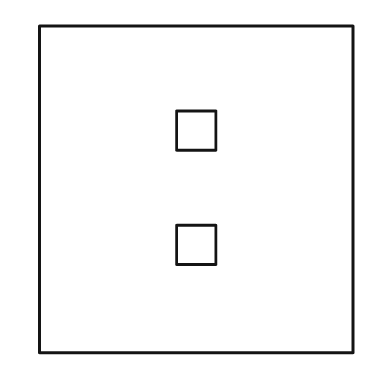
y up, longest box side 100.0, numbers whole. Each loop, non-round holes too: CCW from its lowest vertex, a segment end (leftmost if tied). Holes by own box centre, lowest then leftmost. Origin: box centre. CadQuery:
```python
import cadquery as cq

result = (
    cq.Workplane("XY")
    .moveTo(-48.0, -50.0)
    .lineTo(48.0, -50.0)
    .lineTo(48.0, 50.0)
    .lineTo(-48.0, 50.0)
    .close()
    .moveTo(-6.0, -23.0)
    .lineTo(6.0, -23.0)
    .lineTo(6.0, -11.0)
    .lineTo(-6.0, -11.0)
    .close()
    .moveTo(-6.0, 12.0)
    .lineTo(6.0, 12.0)
    .lineTo(6.0, 24.0)
    .lineTo(-6.0, 24.0)
    .close()
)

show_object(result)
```